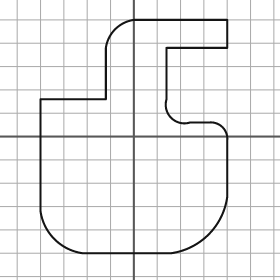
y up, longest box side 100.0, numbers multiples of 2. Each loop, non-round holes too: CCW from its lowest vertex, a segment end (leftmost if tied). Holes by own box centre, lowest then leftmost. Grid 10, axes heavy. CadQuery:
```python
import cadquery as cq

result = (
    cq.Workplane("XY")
    .moveTo(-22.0, -50.0)
    .lineTo(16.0, -50.0)
    .threePointArc((32.0, -42.0), (40.0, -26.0))
    .lineTo(40.0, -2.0)
    .threePointArc((38.0, 4.0), (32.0, 6.0))
    .lineTo(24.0, 6.0)
    .threePointArc((16.0, 8.0), (14.0, 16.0))
    .lineTo(14.0, 38.0)
    .lineTo(40.0, 38.0)
    .lineTo(40.0, 50.0)
    .lineTo(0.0, 50.0)
    .threePointArc((-8.0, 46.0), (-12.0, 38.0))
    .lineTo(-12.0, 16.0)
    .lineTo(-40.0, 16.0)
    .lineTo(-40.0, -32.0)
    .threePointArc((-34.0, -44.0), (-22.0, -50.0))
    .close()
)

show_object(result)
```